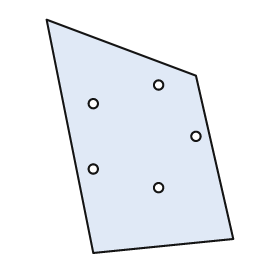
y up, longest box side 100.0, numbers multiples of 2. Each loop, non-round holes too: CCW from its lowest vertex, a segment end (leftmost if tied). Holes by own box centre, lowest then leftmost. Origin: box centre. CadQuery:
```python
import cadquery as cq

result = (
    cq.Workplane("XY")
    .moveTo(-20.0, -50.0)
    .lineTo(40.0, -44.0)
    .lineTo(24.0, 26.0)
    .lineTo(-40.0, 50.0)
    .close()
    .moveTo(8.0, -22.0)
    .circle(2.0)
    .moveTo(-20.0, -14.0)
    .circle(2.0)
    .moveTo(24.0, 0.0)
    .circle(2.0)
    .moveTo(-20.0, 14.0)
    .circle(2.0)
    .moveTo(8.0, 22.0)
    .circle(2.0)
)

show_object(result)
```